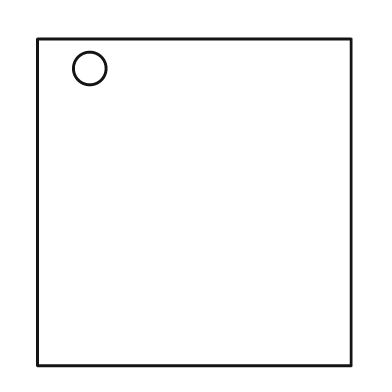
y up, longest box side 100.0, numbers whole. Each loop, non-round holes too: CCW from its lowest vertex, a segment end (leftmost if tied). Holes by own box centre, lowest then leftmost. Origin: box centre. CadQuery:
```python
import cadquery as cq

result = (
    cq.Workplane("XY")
    .moveTo(-48.0, -50.0)
    .lineTo(48.0, -50.0)
    .lineTo(48.0, 50.0)
    .lineTo(-48.0, 50.0)
    .close()
    .moveTo(-32.0, 41.0)
    .circle(5.0)
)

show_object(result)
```